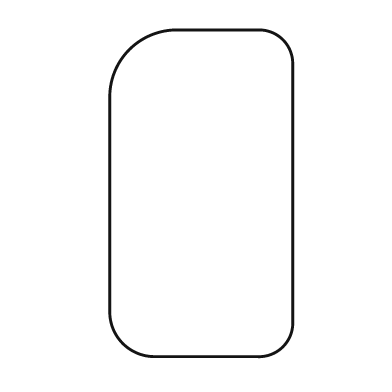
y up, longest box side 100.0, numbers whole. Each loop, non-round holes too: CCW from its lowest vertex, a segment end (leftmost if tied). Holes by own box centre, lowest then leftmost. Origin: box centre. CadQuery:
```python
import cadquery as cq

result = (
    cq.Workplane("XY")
    .moveTo(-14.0, -50.0)
    .lineTo(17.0, -50.0)
    .threePointArc((25.0, -47.0), (28.0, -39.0))
    .lineTo(28.0, 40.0)
    .threePointArc((25.0, 47.0), (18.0, 50.0))
    .lineTo(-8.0, 50.0)
    .threePointArc((-22.0, 44.0), (-28.0, 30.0))
    .lineTo(-28.0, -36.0)
    .threePointArc((-24.0, -46.0), (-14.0, -50.0))
    .close()
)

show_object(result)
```